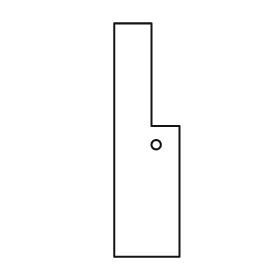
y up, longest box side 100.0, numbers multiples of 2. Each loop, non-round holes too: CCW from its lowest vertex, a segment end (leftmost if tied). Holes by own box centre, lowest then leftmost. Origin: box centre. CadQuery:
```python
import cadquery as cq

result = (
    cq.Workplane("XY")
    .moveTo(-14.0, -50.0)
    .lineTo(14.0, -50.0)
    .lineTo(14.0, 6.0)
    .lineTo(2.0, 6.0)
    .lineTo(2.0, 50.0)
    .lineTo(-14.0, 50.0)
    .close()
    .moveTo(4.0, -2.0)
    .circle(2.0)
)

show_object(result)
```